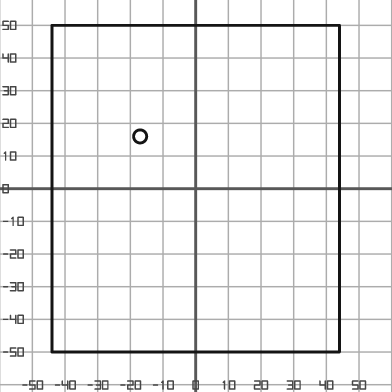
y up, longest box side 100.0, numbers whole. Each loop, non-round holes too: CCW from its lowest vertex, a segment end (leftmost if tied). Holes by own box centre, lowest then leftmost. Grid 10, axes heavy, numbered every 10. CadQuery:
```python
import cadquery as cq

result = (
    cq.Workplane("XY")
    .moveTo(-44.0, -50.0)
    .lineTo(44.0, -50.0)
    .lineTo(44.0, 50.0)
    .lineTo(-44.0, 50.0)
    .close()
    .moveTo(-17.0, 16.0)
    .circle(2.0)
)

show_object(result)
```